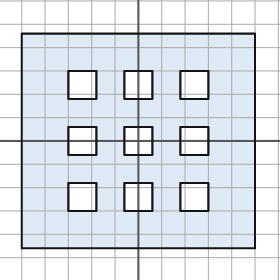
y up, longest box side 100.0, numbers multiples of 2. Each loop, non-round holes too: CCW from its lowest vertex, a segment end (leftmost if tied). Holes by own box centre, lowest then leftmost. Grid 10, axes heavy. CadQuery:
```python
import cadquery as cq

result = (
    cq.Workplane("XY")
    .moveTo(-50.0, -46.0)
    .lineTo(50.0, -46.0)
    .lineTo(50.0, 46.0)
    .lineTo(-50.0, 46.0)
    .close()
    .moveTo(-30.0, -30.0)
    .lineTo(-18.0, -30.0)
    .lineTo(-18.0, -18.0)
    .lineTo(-30.0, -18.0)
    .close()
    .moveTo(-6.0, -30.0)
    .lineTo(6.0, -30.0)
    .lineTo(6.0, -18.0)
    .lineTo(-6.0, -18.0)
    .close()
    .moveTo(18.0, -30.0)
    .lineTo(30.0, -30.0)
    .lineTo(30.0, -18.0)
    .lineTo(18.0, -18.0)
    .close()
    .moveTo(-30.0, -6.0)
    .lineTo(-18.0, -6.0)
    .lineTo(-18.0, 6.0)
    .lineTo(-30.0, 6.0)
    .close()
    .moveTo(-6.0, -6.0)
    .lineTo(6.0, -6.0)
    .lineTo(6.0, 6.0)
    .lineTo(-6.0, 6.0)
    .close()
    .moveTo(18.0, -6.0)
    .lineTo(30.0, -6.0)
    .lineTo(30.0, 6.0)
    .lineTo(18.0, 6.0)
    .close()
    .moveTo(-30.0, 18.0)
    .lineTo(-18.0, 18.0)
    .lineTo(-18.0, 30.0)
    .lineTo(-30.0, 30.0)
    .close()
    .moveTo(-6.0, 18.0)
    .lineTo(6.0, 18.0)
    .lineTo(6.0, 30.0)
    .lineTo(-6.0, 30.0)
    .close()
    .moveTo(18.0, 18.0)
    .lineTo(30.0, 18.0)
    .lineTo(30.0, 30.0)
    .lineTo(18.0, 30.0)
    .close()
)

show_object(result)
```